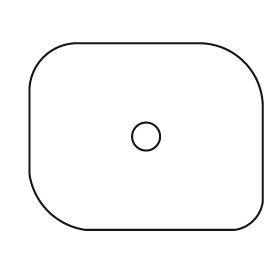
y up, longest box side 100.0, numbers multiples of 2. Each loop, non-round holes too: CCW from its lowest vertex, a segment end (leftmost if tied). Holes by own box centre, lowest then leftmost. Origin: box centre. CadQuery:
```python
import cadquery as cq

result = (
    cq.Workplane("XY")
    .moveTo(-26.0, -40.0)
    .lineTo(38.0, -40.0)
    .threePointArc((46.0, -36.0), (50.0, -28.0))
    .lineTo(50.0, 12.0)
    .threePointArc((42.0, 32.0), (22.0, 40.0))
    .lineTo(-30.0, 40.0)
    .threePointArc((-44.0, 34.0), (-50.0, 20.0))
    .lineTo(-50.0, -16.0)
    .threePointArc((-42.0, -32.0), (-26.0, -40.0))
    .close()
    .moveTo(0.0, 0.0)
    .circle(6.0)
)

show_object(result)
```